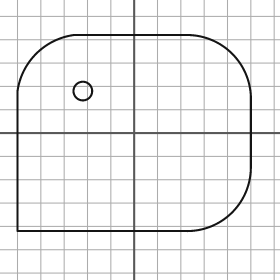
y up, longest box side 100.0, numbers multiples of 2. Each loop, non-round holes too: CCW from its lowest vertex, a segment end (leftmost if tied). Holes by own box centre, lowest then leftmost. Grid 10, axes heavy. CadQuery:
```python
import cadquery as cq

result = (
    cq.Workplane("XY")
    .moveTo(-50.0, -42.0)
    .lineTo(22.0, -42.0)
    .threePointArc((42.0, -34.0), (50.0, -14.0))
    .lineTo(50.0, 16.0)
    .threePointArc((42.0, 34.0), (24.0, 42.0))
    .lineTo(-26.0, 42.0)
    .threePointArc((-42.0, 34.0), (-50.0, 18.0))
    .close()
    .moveTo(-22.0, 18.0)
    .circle(4.0)
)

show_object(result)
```